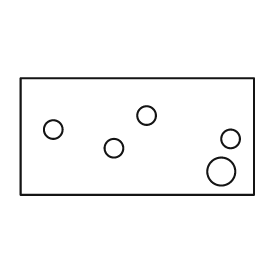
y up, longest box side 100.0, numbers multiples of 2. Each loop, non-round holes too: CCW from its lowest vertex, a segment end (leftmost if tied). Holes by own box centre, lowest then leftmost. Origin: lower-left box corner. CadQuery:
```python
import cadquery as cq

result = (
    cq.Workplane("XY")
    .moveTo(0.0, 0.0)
    .lineTo(100.0, 0.0)
    .lineTo(100.0, 50.0)
    .lineTo(0.0, 50.0)
    .close()
    .moveTo(86.0, 10.0)
    .circle(6.0)
    .moveTo(40.0, 20.0)
    .circle(4.0)
    .moveTo(90.0, 24.0)
    .circle(4.0)
    .moveTo(14.0, 28.0)
    .circle(4.0)
    .moveTo(54.0, 34.0)
    .circle(4.0)
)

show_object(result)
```